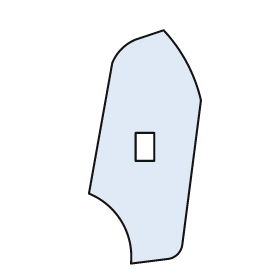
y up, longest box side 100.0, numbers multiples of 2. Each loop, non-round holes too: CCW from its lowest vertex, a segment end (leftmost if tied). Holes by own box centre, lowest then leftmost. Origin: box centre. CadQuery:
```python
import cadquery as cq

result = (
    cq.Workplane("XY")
    .moveTo(-6.0, -50.0)
    .lineTo(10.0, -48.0)
    .threePointArc((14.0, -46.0), (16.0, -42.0))
    .lineTo(24.0, 20.0)
    .threePointArc((18.0, 36.0), (8.0, 50.0))
    .lineTo(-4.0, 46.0)
    .threePointArc((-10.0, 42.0), (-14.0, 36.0))
    .lineTo(-24.0, -20.0)
    .threePointArc((-10.0, -32.0), (-6.0, -50.0))
    .close()
    .moveTo(-4.0, -6.0)
    .lineTo(4.0, -6.0)
    .lineTo(4.0, 6.0)
    .lineTo(-4.0, 6.0)
    .close()
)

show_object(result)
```